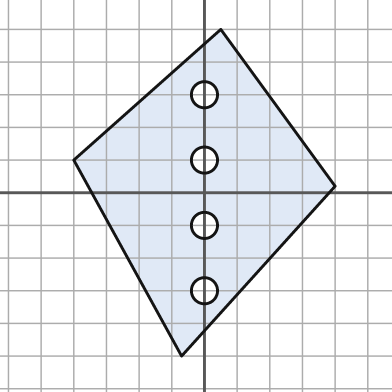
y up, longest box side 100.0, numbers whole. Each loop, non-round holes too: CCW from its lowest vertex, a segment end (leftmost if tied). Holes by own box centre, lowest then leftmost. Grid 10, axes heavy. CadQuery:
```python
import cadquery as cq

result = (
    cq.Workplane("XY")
    .moveTo(-7.0, -50.0)
    .lineTo(40.0, 2.0)
    .lineTo(5.0, 50.0)
    .lineTo(-40.0, 10.0)
    .close()
    .moveTo(0.0, -30.0)
    .circle(4.0)
    .moveTo(0.0, -10.0)
    .circle(4.0)
    .moveTo(0.0, 10.0)
    .circle(4.0)
    .moveTo(0.0, 30.0)
    .circle(4.0)
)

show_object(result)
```